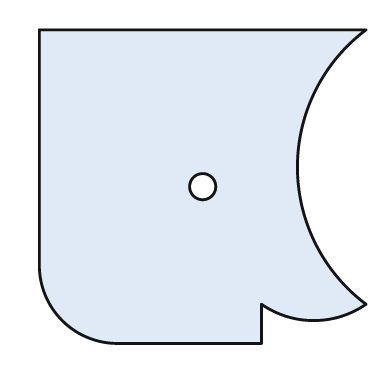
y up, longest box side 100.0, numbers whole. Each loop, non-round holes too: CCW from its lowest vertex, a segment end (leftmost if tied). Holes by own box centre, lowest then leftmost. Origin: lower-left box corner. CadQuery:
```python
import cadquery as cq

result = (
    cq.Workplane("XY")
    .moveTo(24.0, 0.0)
    .lineTo(68.0, 0.0)
    .lineTo(68.0, 12.0)
    .threePointArc((84.0, 7.0), (100.0, 12.0))
    .threePointArc((79.0, 54.0), (100.0, 96.0))
    .lineTo(0.0, 96.0)
    .lineTo(0.0, 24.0)
    .threePointArc((7.0, 7.0), (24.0, 0.0))
    .close()
    .moveTo(50.0, 48.0)
    .circle(4.0)
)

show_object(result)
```